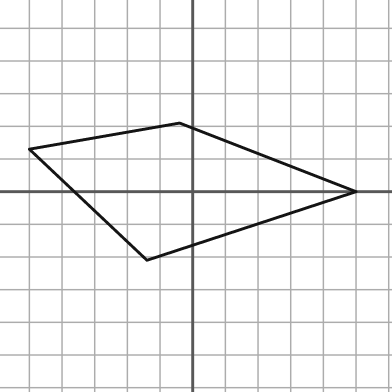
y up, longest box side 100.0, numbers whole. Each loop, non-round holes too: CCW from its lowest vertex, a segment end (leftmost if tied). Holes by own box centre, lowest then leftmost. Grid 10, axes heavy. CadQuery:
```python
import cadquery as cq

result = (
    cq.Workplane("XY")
    .moveTo(-14.0, -21.0)
    .lineTo(50.0, 0.0)
    .lineTo(-4.0, 21.0)
    .lineTo(-50.0, 13.0)
    .close()
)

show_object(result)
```